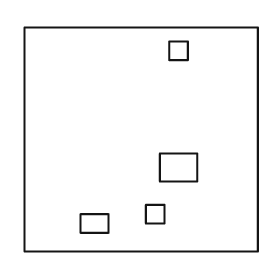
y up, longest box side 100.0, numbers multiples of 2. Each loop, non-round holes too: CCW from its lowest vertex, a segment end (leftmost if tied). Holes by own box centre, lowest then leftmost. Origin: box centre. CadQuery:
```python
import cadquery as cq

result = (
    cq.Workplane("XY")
    .moveTo(-50.0, -48.0)
    .lineTo(50.0, -48.0)
    .lineTo(50.0, 48.0)
    .lineTo(-50.0, 48.0)
    .close()
    .moveTo(-26.0, -40.0)
    .lineTo(-14.0, -40.0)
    .lineTo(-14.0, -32.0)
    .lineTo(-26.0, -32.0)
    .close()
    .moveTo(2.0, -36.0)
    .lineTo(10.0, -36.0)
    .lineTo(10.0, -28.0)
    .lineTo(2.0, -28.0)
    .close()
    .moveTo(8.0, -18.0)
    .lineTo(24.0, -18.0)
    .lineTo(24.0, -6.0)
    .lineTo(8.0, -6.0)
    .close()
    .moveTo(12.0, 34.0)
    .lineTo(20.0, 34.0)
    .lineTo(20.0, 42.0)
    .lineTo(12.0, 42.0)
    .close()
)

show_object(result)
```